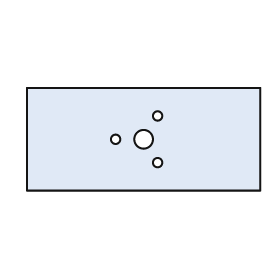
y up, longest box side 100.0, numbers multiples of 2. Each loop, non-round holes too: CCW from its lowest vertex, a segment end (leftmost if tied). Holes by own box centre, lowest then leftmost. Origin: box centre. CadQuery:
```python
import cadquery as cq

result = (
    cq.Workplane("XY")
    .moveTo(-50.0, -22.0)
    .lineTo(50.0, -22.0)
    .lineTo(50.0, 22.0)
    .lineTo(-50.0, 22.0)
    .close()
    .moveTo(6.0, -10.0)
    .circle(2.0)
    .moveTo(-12.0, 0.0)
    .circle(2.0)
    .moveTo(0.0, 0.0)
    .circle(4.0)
    .moveTo(6.0, 10.0)
    .circle(2.0)
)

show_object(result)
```